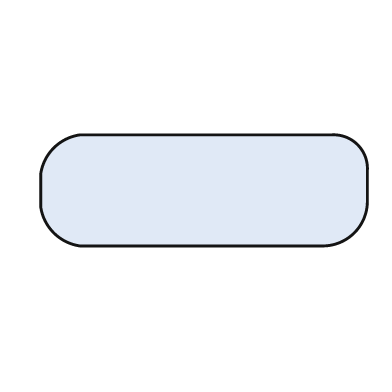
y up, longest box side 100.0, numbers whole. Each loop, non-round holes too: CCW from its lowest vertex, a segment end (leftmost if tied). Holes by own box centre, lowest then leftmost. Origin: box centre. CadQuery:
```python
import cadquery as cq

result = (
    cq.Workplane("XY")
    .moveTo(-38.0, -17.0)
    .lineTo(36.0, -17.0)
    .threePointArc((46.0, -13.0), (50.0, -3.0))
    .lineTo(50.0, 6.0)
    .threePointArc((47.0, 14.0), (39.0, 17.0))
    .lineTo(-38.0, 17.0)
    .threePointArc((-46.0, 13.0), (-50.0, 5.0))
    .lineTo(-50.0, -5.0)
    .threePointArc((-46.0, -13.0), (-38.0, -17.0))
    .close()
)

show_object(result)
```